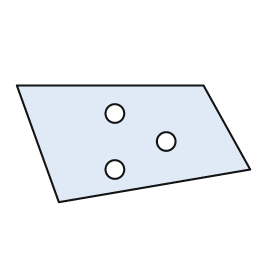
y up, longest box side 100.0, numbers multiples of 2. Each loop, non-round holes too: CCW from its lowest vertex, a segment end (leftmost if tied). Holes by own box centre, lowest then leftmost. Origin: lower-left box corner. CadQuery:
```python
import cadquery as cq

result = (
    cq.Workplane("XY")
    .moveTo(18.0, 0.0)
    .lineTo(100.0, 14.0)
    .lineTo(80.0, 50.0)
    .lineTo(0.0, 50.0)
    .close()
    .moveTo(42.0, 14.0)
    .circle(4.0)
    .moveTo(64.0, 26.0)
    .circle(4.0)
    .moveTo(42.0, 38.0)
    .circle(4.0)
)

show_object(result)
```